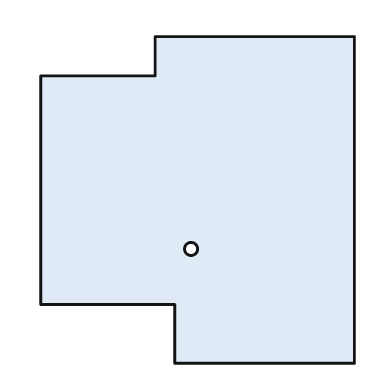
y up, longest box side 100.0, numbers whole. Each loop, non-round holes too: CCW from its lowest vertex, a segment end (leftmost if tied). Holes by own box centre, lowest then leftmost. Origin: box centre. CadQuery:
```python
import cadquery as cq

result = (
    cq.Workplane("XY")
    .moveTo(-7.0, -50.0)
    .lineTo(48.0, -50.0)
    .lineTo(48.0, 50.0)
    .lineTo(-13.0, 50.0)
    .lineTo(-13.0, 38.0)
    .lineTo(-48.0, 38.0)
    .lineTo(-48.0, -32.0)
    .lineTo(-7.0, -32.0)
    .close()
    .moveTo(-2.0, -15.0)
    .circle(2.0)
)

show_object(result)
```